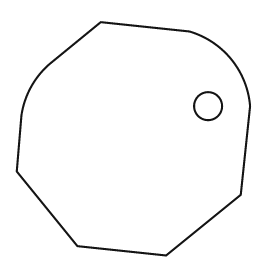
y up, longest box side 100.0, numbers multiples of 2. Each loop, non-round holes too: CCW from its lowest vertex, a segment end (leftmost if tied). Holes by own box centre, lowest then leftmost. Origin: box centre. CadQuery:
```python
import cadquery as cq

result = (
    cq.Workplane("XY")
    .moveTo(14.0, -50.0)
    .lineTo(46.0, -24.0)
    .lineTo(50.0, 14.0)
    .threePointArc((42.0, 34.0), (24.0, 46.0))
    .lineTo(-14.0, 50.0)
    .lineTo(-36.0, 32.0)
    .threePointArc((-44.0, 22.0), (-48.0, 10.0))
    .lineTo(-50.0, -14.0)
    .lineTo(-24.0, -46.0)
    .close()
    .moveTo(32.0, 14.0)
    .circle(6.0)
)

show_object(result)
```